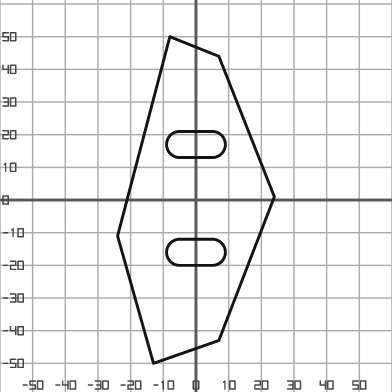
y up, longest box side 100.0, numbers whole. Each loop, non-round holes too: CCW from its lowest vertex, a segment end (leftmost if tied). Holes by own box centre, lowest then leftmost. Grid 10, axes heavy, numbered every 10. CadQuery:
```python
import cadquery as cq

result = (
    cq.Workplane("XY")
    .moveTo(-13.0, -50.0)
    .lineTo(7.0, -43.0)
    .lineTo(24.0, 1.0)
    .lineTo(7.0, 44.0)
    .lineTo(-8.0, 50.0)
    .lineTo(-24.0, -11.0)
    .close()
    .moveTo(-5.0, -20.0)
    .lineTo(5.0, -20.0)
    .threePointArc((9.0, -16.0), (5.0, -12.0))
    .lineTo(-5.0, -12.0)
    .threePointArc((-9.0, -16.0), (-5.0, -20.0))
    .close()
    .moveTo(-5.0, 13.0)
    .lineTo(5.0, 13.0)
    .threePointArc((9.0, 17.0), (5.0, 21.0))
    .lineTo(-5.0, 21.0)
    .threePointArc((-9.0, 17.0), (-5.0, 13.0))
    .close()
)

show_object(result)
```